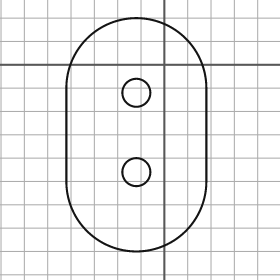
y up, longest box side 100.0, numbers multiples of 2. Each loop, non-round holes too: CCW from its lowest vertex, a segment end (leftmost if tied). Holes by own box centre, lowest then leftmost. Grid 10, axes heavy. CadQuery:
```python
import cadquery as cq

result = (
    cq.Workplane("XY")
    .moveTo(-42.0, -50.0)
    .threePointArc((-12.0, -80.0), (18.0, -50.0))
    .lineTo(18.0, -10.0)
    .threePointArc((-12.0, 20.0), (-42.0, -10.0))
    .close()
    .moveTo(-12.0, -46.0)
    .circle(6.0)
    .moveTo(-12.0, -12.0)
    .circle(6.0)
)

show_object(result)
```